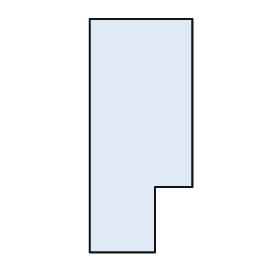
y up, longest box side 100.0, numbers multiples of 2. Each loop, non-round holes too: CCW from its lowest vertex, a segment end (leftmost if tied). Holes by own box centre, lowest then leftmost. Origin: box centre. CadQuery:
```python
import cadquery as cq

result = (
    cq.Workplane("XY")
    .moveTo(-22.0, -50.0)
    .lineTo(6.0, -50.0)
    .lineTo(6.0, -22.0)
    .lineTo(22.0, -22.0)
    .lineTo(22.0, 50.0)
    .lineTo(-22.0, 50.0)
    .close()
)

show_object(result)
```